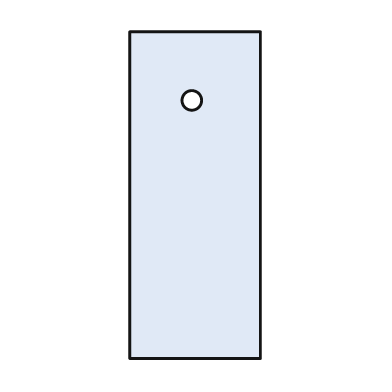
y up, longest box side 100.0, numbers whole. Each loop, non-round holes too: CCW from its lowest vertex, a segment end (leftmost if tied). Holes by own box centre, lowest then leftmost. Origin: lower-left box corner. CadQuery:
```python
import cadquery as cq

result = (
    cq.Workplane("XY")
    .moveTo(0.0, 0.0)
    .lineTo(40.0, 0.0)
    .lineTo(40.0, 100.0)
    .lineTo(0.0, 100.0)
    .close()
    .moveTo(19.0, 79.0)
    .circle(3.0)
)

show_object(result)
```